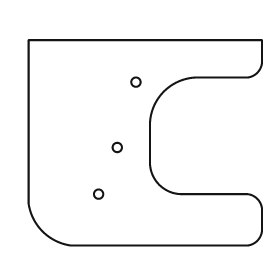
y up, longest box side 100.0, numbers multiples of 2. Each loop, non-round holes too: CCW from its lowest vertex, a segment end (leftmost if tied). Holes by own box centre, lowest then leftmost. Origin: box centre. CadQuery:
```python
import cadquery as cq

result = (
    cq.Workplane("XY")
    .moveTo(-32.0, -44.0)
    .lineTo(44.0, -44.0)
    .threePointArc((48.0, -42.0), (50.0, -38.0))
    .lineTo(50.0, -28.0)
    .threePointArc((48.0, -24.0), (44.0, -22.0))
    .lineTo(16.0, -22.0)
    .threePointArc((6.0, -18.0), (2.0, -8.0))
    .lineTo(2.0, 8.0)
    .threePointArc((8.0, 22.0), (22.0, 28.0))
    .lineTo(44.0, 28.0)
    .threePointArc((48.0, 30.0), (50.0, 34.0))
    .lineTo(50.0, 44.0)
    .lineTo(-50.0, 44.0)
    .lineTo(-50.0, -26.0)
    .threePointArc((-44.0, -38.0), (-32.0, -44.0))
    .close()
    .moveTo(-20.0, -22.0)
    .circle(2.0)
    .moveTo(-12.0, -2.0)
    .circle(2.0)
    .moveTo(-4.0, 26.0)
    .circle(2.0)
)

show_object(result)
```